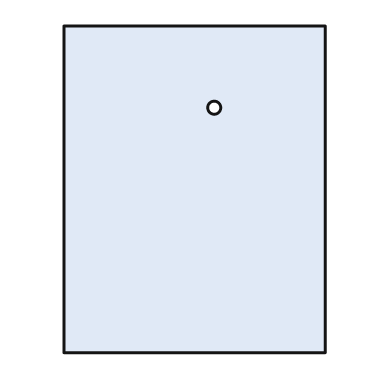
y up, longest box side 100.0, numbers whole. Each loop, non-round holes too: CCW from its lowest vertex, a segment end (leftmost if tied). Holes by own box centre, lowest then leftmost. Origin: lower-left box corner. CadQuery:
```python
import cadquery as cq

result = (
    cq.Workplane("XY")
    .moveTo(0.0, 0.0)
    .lineTo(80.0, 0.0)
    .lineTo(80.0, 100.0)
    .lineTo(0.0, 100.0)
    .close()
    .moveTo(46.0, 75.0)
    .circle(2.0)
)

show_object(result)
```